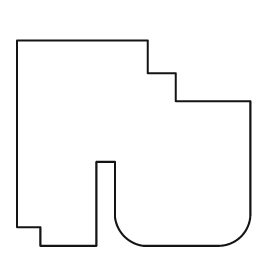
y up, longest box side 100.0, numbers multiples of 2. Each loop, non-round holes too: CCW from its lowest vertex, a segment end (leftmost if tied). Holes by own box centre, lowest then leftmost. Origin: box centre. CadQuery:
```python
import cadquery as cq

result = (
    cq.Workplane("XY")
    .moveTo(-40.0, -44.0)
    .lineTo(-16.0, -44.0)
    .lineTo(-16.0, -8.0)
    .lineTo(-8.0, -8.0)
    .lineTo(-8.0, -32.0)
    .threePointArc((-4.0, -40.0), (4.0, -44.0))
    .lineTo(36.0, -44.0)
    .threePointArc((46.0, -40.0), (50.0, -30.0))
    .lineTo(50.0, 18.0)
    .lineTo(18.0, 18.0)
    .lineTo(18.0, 30.0)
    .lineTo(6.0, 30.0)
    .lineTo(6.0, 44.0)
    .lineTo(-50.0, 44.0)
    .lineTo(-50.0, -36.0)
    .lineTo(-40.0, -36.0)
    .close()
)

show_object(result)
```